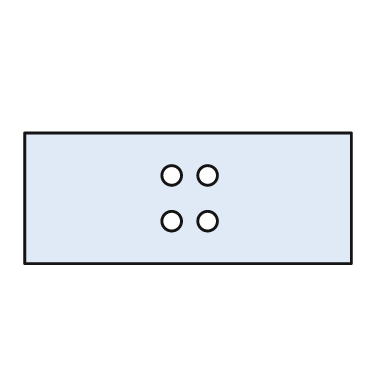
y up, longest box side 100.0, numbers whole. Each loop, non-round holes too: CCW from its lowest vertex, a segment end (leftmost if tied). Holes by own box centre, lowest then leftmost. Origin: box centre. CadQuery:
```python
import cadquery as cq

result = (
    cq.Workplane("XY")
    .moveTo(-50.0, -20.0)
    .lineTo(50.0, -20.0)
    .lineTo(50.0, 20.0)
    .lineTo(-50.0, 20.0)
    .close()
    .moveTo(-5.0, -7.0)
    .circle(3.0)
    .moveTo(6.0, -7.0)
    .circle(3.0)
    .moveTo(-5.0, 7.0)
    .circle(3.0)
    .moveTo(6.0, 7.0)
    .circle(3.0)
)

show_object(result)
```